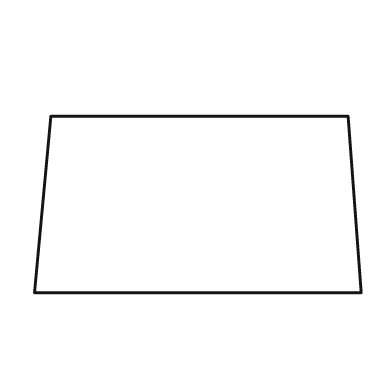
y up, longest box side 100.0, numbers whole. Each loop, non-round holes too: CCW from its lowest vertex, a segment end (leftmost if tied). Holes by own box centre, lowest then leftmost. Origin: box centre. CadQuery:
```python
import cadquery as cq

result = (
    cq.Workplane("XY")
    .moveTo(-50.0, -27.0)
    .lineTo(50.0, -27.0)
    .lineTo(46.0, 27.0)
    .lineTo(-45.0, 27.0)
    .close()
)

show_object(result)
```